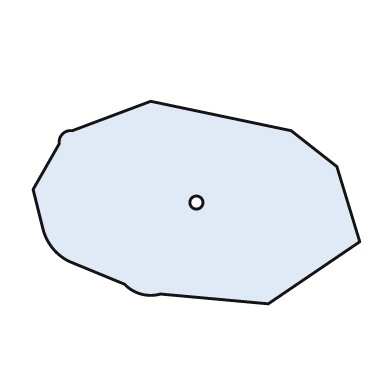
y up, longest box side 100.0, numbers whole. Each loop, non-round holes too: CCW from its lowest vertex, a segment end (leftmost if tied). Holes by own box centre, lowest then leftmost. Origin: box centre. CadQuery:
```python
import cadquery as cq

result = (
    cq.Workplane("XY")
    .moveTo(22.0, -31.0)
    .lineTo(50.0, -12.0)
    .lineTo(43.0, 11.0)
    .lineTo(29.0, 22.0)
    .lineTo(-14.0, 31.0)
    .lineTo(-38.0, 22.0)
    .threePointArc((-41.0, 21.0), (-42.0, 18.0))
    .lineTo(-50.0, 4.0)
    .lineTo(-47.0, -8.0)
    .threePointArc((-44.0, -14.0), (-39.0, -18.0))
    .lineTo(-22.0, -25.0)
    .threePointArc((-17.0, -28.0), (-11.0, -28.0))
    .close()
    .moveTo(0.0, 0.0)
    .circle(2.0)
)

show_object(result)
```